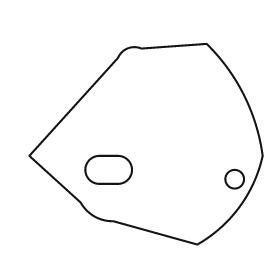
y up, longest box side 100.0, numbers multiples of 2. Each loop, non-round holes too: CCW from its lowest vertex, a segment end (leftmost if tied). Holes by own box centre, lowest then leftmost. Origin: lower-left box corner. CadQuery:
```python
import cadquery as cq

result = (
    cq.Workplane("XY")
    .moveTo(72.0, 0.0)
    .threePointArc((90.0, 16.0), (100.0, 38.0))
    .threePointArc((92.0, 64.0), (76.0, 86.0))
    .lineTo(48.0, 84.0)
    .threePointArc((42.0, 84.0), (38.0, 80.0))
    .lineTo(0.0, 38.0)
    .lineTo(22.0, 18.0)
    .threePointArc((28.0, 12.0), (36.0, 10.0))
    .close()
    .moveTo(88.0, 28.0)
    .circle(4.0)
    .moveTo(30.0, 26.0)
    .lineTo(38.0, 26.0)
    .threePointArc((44.0, 32.0), (38.0, 38.0))
    .lineTo(30.0, 38.0)
    .threePointArc((24.0, 32.0), (30.0, 26.0))
    .close()
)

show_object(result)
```